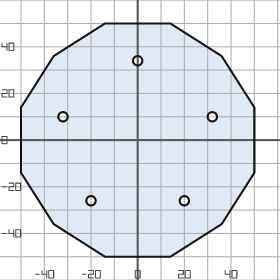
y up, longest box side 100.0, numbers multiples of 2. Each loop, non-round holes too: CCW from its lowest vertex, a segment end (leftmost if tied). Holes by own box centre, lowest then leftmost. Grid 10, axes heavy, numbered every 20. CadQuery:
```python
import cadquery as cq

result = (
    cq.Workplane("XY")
    .moveTo(-14.0, -50.0)
    .lineTo(14.0, -50.0)
    .lineTo(36.0, -36.0)
    .lineTo(50.0, -14.0)
    .lineTo(50.0, 14.0)
    .lineTo(36.0, 36.0)
    .lineTo(14.0, 50.0)
    .lineTo(-14.0, 50.0)
    .lineTo(-36.0, 36.0)
    .lineTo(-50.0, 14.0)
    .lineTo(-50.0, -14.0)
    .lineTo(-36.0, -36.0)
    .close()
    .moveTo(-20.0, -26.0)
    .circle(2.0)
    .moveTo(20.0, -26.0)
    .circle(2.0)
    .moveTo(-32.0, 10.0)
    .circle(2.0)
    .moveTo(32.0, 10.0)
    .circle(2.0)
    .moveTo(0.0, 34.0)
    .circle(2.0)
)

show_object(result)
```